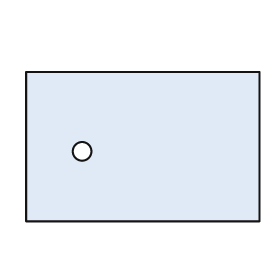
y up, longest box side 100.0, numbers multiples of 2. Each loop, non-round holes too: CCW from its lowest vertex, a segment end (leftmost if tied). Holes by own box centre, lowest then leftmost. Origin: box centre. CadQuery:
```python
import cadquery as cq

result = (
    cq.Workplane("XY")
    .moveTo(-50.0, -32.0)
    .lineTo(50.0, -32.0)
    .lineTo(50.0, 32.0)
    .lineTo(-50.0, 32.0)
    .close()
    .moveTo(-26.0, -2.0)
    .circle(4.0)
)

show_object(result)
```